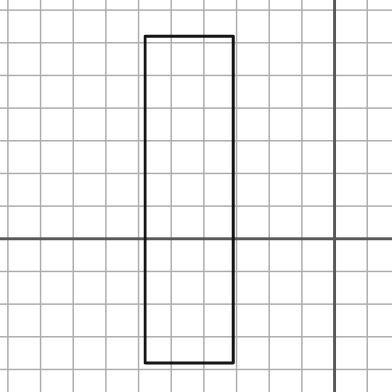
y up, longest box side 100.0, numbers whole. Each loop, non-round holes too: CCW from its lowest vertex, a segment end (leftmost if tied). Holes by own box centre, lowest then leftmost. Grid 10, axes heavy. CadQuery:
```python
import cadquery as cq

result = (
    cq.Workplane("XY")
    .moveTo(-58.0, -38.0)
    .lineTo(-31.0, -38.0)
    .lineTo(-31.0, 62.0)
    .lineTo(-58.0, 62.0)
    .close()
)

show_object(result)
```